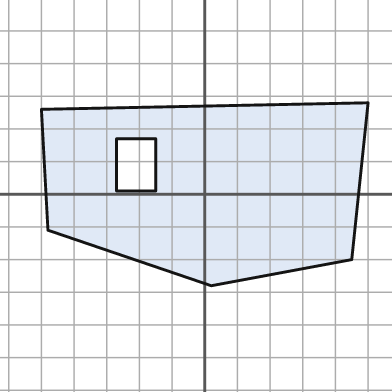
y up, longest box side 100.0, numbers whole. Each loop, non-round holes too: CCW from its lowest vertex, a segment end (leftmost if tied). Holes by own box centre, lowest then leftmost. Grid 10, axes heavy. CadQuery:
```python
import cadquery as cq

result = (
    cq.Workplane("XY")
    .moveTo(2.0, -28.0)
    .lineTo(45.0, -20.0)
    .lineTo(50.0, 28.0)
    .lineTo(-50.0, 26.0)
    .lineTo(-48.0, -11.0)
    .close()
    .moveTo(-27.0, 1.0)
    .lineTo(-15.0, 1.0)
    .lineTo(-15.0, 17.0)
    .lineTo(-27.0, 17.0)
    .close()
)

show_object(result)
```